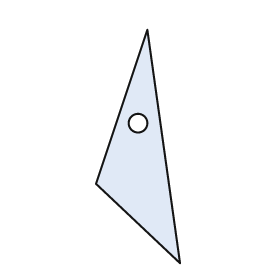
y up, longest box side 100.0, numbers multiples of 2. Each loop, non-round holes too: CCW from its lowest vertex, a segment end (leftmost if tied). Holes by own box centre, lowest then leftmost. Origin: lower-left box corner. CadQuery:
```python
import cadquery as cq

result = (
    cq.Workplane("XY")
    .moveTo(36.0, 0.0)
    .lineTo(22.0, 100.0)
    .lineTo(0.0, 34.0)
    .close()
    .moveTo(18.0, 60.0)
    .circle(4.0)
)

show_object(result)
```